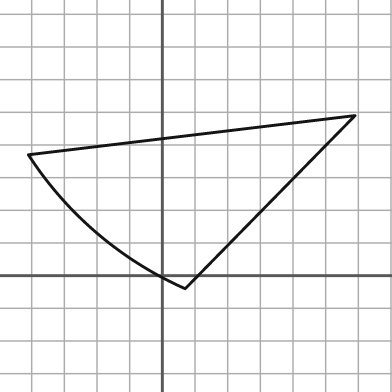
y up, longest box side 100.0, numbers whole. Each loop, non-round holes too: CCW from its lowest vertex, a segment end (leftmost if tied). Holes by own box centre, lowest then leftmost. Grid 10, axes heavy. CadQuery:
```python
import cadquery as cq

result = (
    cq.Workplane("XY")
    .moveTo(7.0, -4.0)
    .lineTo(59.0, 49.0)
    .lineTo(-41.0, 37.0)
    .threePointArc((-20.0, 13.0), (7.0, -4.0))
    .close()
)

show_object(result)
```